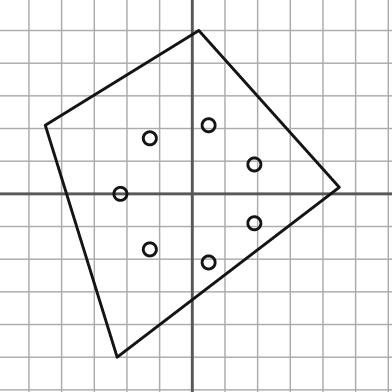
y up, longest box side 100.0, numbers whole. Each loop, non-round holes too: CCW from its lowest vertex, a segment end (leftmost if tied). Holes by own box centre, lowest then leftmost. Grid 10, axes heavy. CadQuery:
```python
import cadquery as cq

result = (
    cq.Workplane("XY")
    .moveTo(-23.0, -50.0)
    .lineTo(45.0, 2.0)
    .lineTo(2.0, 50.0)
    .lineTo(-45.0, 21.0)
    .close()
    .moveTo(5.0, -21.0)
    .circle(2.0)
    .moveTo(-13.0, -17.0)
    .circle(2.0)
    .moveTo(19.0, -9.0)
    .circle(2.0)
    .moveTo(-22.0, 0.0)
    .circle(2.0)
    .moveTo(19.0, 9.0)
    .circle(2.0)
    .moveTo(-13.0, 17.0)
    .circle(2.0)
    .moveTo(5.0, 21.0)
    .circle(2.0)
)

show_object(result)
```